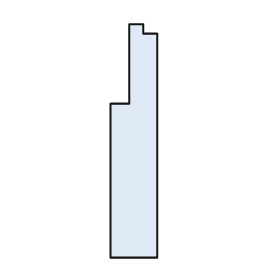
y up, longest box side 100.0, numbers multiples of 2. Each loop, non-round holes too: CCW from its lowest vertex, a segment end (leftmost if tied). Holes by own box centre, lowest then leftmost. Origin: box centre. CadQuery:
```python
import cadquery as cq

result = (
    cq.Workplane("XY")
    .moveTo(-10.0, -50.0)
    .lineTo(10.0, -50.0)
    .lineTo(10.0, 46.0)
    .lineTo(4.0, 46.0)
    .lineTo(4.0, 50.0)
    .lineTo(-2.0, 50.0)
    .lineTo(-2.0, 16.0)
    .lineTo(-10.0, 16.0)
    .close()
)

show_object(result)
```